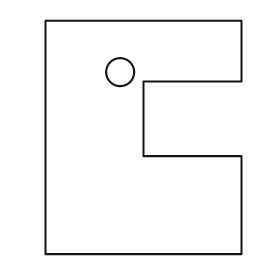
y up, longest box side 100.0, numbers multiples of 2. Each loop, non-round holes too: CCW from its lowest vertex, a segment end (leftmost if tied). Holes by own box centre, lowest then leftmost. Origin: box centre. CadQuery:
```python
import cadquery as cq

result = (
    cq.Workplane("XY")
    .moveTo(-42.0, -50.0)
    .lineTo(42.0, -50.0)
    .lineTo(42.0, -8.0)
    .lineTo(0.0, -8.0)
    .lineTo(0.0, 24.0)
    .lineTo(42.0, 24.0)
    .lineTo(42.0, 50.0)
    .lineTo(-42.0, 50.0)
    .close()
    .moveTo(-10.0, 28.0)
    .circle(6.0)
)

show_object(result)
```